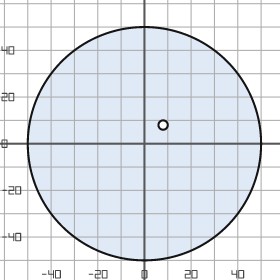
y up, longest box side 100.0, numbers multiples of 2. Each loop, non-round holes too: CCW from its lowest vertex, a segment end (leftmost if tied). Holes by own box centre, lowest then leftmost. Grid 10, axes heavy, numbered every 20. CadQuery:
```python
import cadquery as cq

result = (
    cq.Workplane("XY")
    .moveTo(0.0, 0.0)
    .circle(50.0)
    .moveTo(8.0, 8.0)
    .circle(2.0)
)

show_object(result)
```